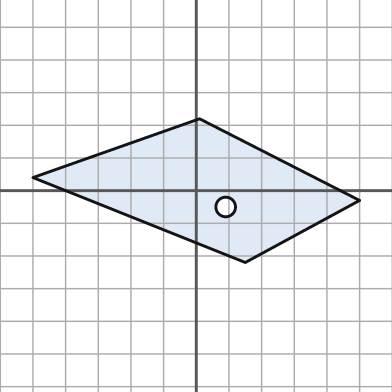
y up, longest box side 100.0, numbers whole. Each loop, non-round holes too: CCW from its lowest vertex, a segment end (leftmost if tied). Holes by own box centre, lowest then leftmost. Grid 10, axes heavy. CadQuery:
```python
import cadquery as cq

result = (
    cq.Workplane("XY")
    .moveTo(15.0, -22.0)
    .lineTo(50.0, -3.0)
    .lineTo(1.0, 22.0)
    .lineTo(-50.0, 4.0)
    .close()
    .moveTo(9.0, -5.0)
    .circle(3.0)
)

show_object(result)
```